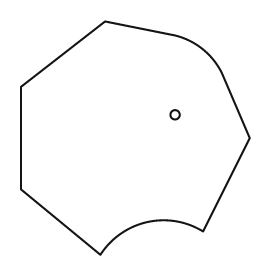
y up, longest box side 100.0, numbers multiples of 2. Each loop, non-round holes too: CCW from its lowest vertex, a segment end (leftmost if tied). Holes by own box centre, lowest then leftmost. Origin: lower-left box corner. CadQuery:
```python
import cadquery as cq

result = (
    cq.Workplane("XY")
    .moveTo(34.0, 0.0)
    .threePointArc((54.0, 14.0), (78.0, 10.0))
    .lineTo(98.0, 50.0)
    .lineTo(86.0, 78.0)
    .threePointArc((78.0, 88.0), (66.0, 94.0))
    .lineTo(36.0, 100.0)
    .lineTo(0.0, 72.0)
    .lineTo(0.0, 28.0)
    .close()
    .moveTo(66.0, 60.0)
    .circle(2.0)
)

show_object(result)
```